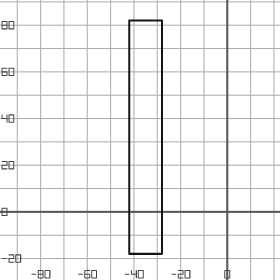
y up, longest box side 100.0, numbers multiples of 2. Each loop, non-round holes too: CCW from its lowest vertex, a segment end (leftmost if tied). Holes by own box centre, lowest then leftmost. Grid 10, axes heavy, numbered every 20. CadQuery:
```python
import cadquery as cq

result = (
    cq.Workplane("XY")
    .moveTo(-42.0, -18.0)
    .lineTo(-28.0, -18.0)
    .lineTo(-28.0, 82.0)
    .lineTo(-42.0, 82.0)
    .close()
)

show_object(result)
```